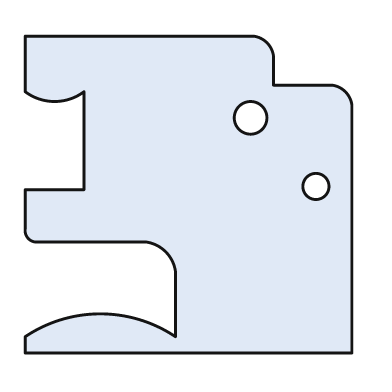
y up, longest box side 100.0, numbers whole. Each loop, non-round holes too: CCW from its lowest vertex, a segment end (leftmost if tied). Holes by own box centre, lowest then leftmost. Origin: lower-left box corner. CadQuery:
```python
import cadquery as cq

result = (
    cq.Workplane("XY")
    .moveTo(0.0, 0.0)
    .lineTo(100.0, 0.0)
    .lineTo(100.0, 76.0)
    .threePointArc((98.0, 80.0), (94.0, 82.0))
    .lineTo(76.0, 82.0)
    .lineTo(76.0, 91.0)
    .threePointArc((74.0, 95.0), (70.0, 97.0))
    .lineTo(0.0, 97.0)
    .lineTo(0.0, 80.0)
    .threePointArc((9.0, 77.0), (18.0, 80.0))
    .lineTo(18.0, 50.0)
    .lineTo(0.0, 50.0)
    .lineTo(0.0, 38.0)
    .threePointArc((1.0, 35.0), (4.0, 34.0))
    .lineTo(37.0, 34.0)
    .threePointArc((43.0, 31.0), (46.0, 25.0))
    .lineTo(46.0, 5.0)
    .threePointArc((23.0, 12.0), (0.0, 5.0))
    .close()
    .moveTo(89.0, 51.0)
    .circle(4.0)
    .moveTo(69.0, 72.0)
    .circle(5.0)
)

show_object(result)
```